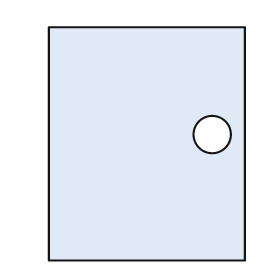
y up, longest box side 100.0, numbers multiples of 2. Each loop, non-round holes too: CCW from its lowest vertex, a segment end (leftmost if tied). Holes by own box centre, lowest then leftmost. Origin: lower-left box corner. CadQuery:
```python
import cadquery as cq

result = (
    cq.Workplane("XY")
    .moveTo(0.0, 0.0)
    .lineTo(84.0, 0.0)
    .lineTo(84.0, 100.0)
    .lineTo(0.0, 100.0)
    .close()
    .moveTo(70.0, 54.0)
    .circle(8.0)
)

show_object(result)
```